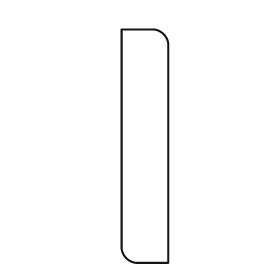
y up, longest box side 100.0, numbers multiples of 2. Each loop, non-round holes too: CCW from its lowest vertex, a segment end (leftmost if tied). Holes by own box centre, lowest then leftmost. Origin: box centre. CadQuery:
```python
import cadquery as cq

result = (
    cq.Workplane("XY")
    .moveTo(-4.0, -50.0)
    .lineTo(10.0, -50.0)
    .lineTo(10.0, 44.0)
    .threePointArc((8.0, 48.0), (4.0, 50.0))
    .lineTo(-10.0, 50.0)
    .lineTo(-10.0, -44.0)
    .threePointArc((-8.0, -48.0), (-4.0, -50.0))
    .close()
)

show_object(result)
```